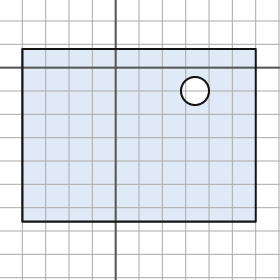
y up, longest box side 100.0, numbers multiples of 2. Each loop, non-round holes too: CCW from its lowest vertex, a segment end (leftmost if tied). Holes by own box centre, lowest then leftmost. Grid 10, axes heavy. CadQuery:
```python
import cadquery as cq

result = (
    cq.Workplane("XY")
    .moveTo(-40.0, -66.0)
    .lineTo(60.0, -66.0)
    .lineTo(60.0, 8.0)
    .lineTo(-40.0, 8.0)
    .close()
    .moveTo(34.0, -10.0)
    .circle(6.0)
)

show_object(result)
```